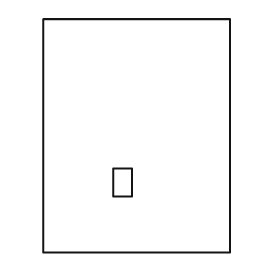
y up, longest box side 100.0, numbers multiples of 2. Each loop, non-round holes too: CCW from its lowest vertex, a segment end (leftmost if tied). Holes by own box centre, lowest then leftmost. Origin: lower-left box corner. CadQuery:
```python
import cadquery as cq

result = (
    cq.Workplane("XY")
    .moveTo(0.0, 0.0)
    .lineTo(80.0, 0.0)
    .lineTo(80.0, 100.0)
    .lineTo(0.0, 100.0)
    .close()
    .moveTo(30.0, 24.0)
    .lineTo(38.0, 24.0)
    .lineTo(38.0, 36.0)
    .lineTo(30.0, 36.0)
    .close()
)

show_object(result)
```